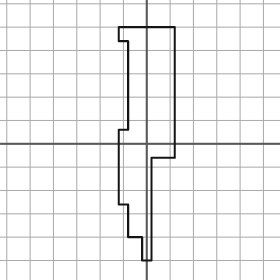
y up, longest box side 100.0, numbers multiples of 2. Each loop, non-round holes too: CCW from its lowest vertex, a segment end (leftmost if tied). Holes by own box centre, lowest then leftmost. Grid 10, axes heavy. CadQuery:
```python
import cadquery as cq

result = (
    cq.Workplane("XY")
    .moveTo(-2.0, -50.0)
    .lineTo(2.0, -50.0)
    .lineTo(2.0, -6.0)
    .lineTo(12.0, -6.0)
    .lineTo(12.0, 50.0)
    .lineTo(-12.0, 50.0)
    .lineTo(-12.0, 44.0)
    .lineTo(-8.0, 44.0)
    .lineTo(-8.0, 6.0)
    .lineTo(-12.0, 6.0)
    .lineTo(-12.0, -26.0)
    .lineTo(-8.0, -26.0)
    .lineTo(-8.0, -40.0)
    .lineTo(-2.0, -40.0)
    .close()
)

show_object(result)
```